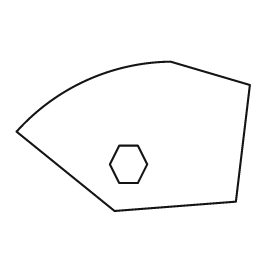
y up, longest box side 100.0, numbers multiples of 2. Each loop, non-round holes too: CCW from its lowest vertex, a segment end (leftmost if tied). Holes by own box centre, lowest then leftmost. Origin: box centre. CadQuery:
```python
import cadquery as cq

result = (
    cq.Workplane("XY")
    .moveTo(-8.0, -32.0)
    .lineTo(44.0, -28.0)
    .lineTo(50.0, 22.0)
    .lineTo(16.0, 32.0)
    .threePointArc((-20.0, 24.0), (-50.0, 2.0))
    .close()
    .moveTo(-6.0, -20.0)
    .lineTo(2.0, -20.0)
    .lineTo(6.0, -12.0)
    .lineTo(2.0, -4.0)
    .lineTo(-6.0, -4.0)
    .lineTo(-10.0, -12.0)
    .close()
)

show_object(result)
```